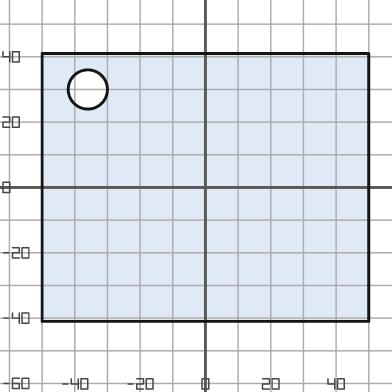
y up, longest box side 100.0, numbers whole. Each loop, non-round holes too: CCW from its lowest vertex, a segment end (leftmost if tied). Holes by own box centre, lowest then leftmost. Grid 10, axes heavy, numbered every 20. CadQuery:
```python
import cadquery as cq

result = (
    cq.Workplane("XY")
    .moveTo(-50.0, -41.0)
    .lineTo(50.0, -41.0)
    .lineTo(50.0, 41.0)
    .lineTo(-50.0, 41.0)
    .close()
    .moveTo(-36.0, 30.0)
    .circle(6.0)
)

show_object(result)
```